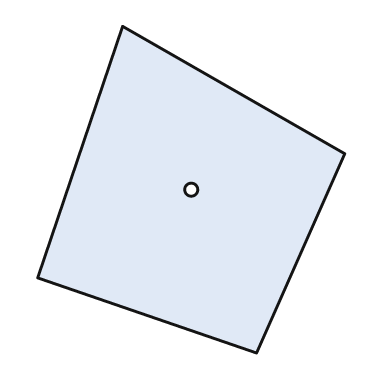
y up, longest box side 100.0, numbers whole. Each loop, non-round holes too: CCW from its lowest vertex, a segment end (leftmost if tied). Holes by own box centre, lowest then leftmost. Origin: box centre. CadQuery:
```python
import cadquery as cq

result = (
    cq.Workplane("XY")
    .moveTo(20.0, -50.0)
    .lineTo(47.0, 11.0)
    .lineTo(-21.0, 50.0)
    .lineTo(-47.0, -27.0)
    .close()
    .moveTo(0.0, 0.0)
    .circle(2.0)
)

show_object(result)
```